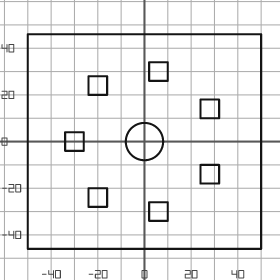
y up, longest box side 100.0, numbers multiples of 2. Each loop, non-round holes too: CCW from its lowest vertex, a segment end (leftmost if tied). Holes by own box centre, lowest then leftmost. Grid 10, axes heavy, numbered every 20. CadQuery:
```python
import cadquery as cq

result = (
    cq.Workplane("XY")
    .moveTo(-50.0, -46.0)
    .lineTo(50.0, -46.0)
    .lineTo(50.0, 46.0)
    .lineTo(-50.0, 46.0)
    .close()
    .moveTo(2.0, -34.0)
    .lineTo(10.0, -34.0)
    .lineTo(10.0, -26.0)
    .lineTo(2.0, -26.0)
    .close()
    .moveTo(-24.0, -28.0)
    .lineTo(-16.0, -28.0)
    .lineTo(-16.0, -20.0)
    .lineTo(-24.0, -20.0)
    .close()
    .moveTo(24.0, -18.0)
    .lineTo(32.0, -18.0)
    .lineTo(32.0, -10.0)
    .lineTo(24.0, -10.0)
    .close()
    .moveTo(-34.0, -4.0)
    .lineTo(-26.0, -4.0)
    .lineTo(-26.0, 4.0)
    .lineTo(-34.0, 4.0)
    .close()
    .moveTo(0.0, 0.0)
    .circle(8.0)
    .moveTo(24.0, 10.0)
    .lineTo(32.0, 10.0)
    .lineTo(32.0, 18.0)
    .lineTo(24.0, 18.0)
    .close()
    .moveTo(-24.0, 20.0)
    .lineTo(-16.0, 20.0)
    .lineTo(-16.0, 28.0)
    .lineTo(-24.0, 28.0)
    .close()
    .moveTo(2.0, 26.0)
    .lineTo(10.0, 26.0)
    .lineTo(10.0, 34.0)
    .lineTo(2.0, 34.0)
    .close()
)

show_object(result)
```